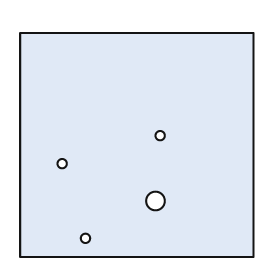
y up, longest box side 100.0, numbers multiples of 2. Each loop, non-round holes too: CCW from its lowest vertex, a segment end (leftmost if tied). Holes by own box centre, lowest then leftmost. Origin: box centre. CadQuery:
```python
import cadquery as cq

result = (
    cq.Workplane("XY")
    .moveTo(-50.0, -48.0)
    .lineTo(50.0, -48.0)
    .lineTo(50.0, 48.0)
    .lineTo(-50.0, 48.0)
    .close()
    .moveTo(-22.0, -40.0)
    .circle(2.0)
    .moveTo(8.0, -24.0)
    .circle(4.0)
    .moveTo(-32.0, -8.0)
    .circle(2.0)
    .moveTo(10.0, 4.0)
    .circle(2.0)
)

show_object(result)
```